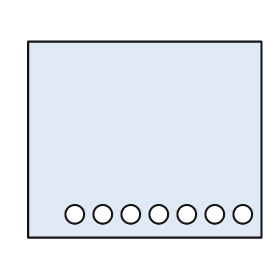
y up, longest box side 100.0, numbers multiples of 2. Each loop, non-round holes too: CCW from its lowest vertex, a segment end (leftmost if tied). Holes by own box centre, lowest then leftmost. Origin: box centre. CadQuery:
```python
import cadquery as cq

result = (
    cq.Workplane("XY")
    .moveTo(-50.0, -42.0)
    .lineTo(50.0, -42.0)
    .lineTo(50.0, 42.0)
    .lineTo(-50.0, 42.0)
    .close()
    .moveTo(-30.0, -32.0)
    .circle(4.0)
    .moveTo(-18.0, -32.0)
    .circle(4.0)
    .moveTo(-6.0, -32.0)
    .circle(4.0)
    .moveTo(6.0, -32.0)
    .circle(4.0)
    .moveTo(18.0, -32.0)
    .circle(4.0)
    .moveTo(30.0, -32.0)
    .circle(4.0)
    .moveTo(42.0, -32.0)
    .circle(4.0)
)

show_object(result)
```